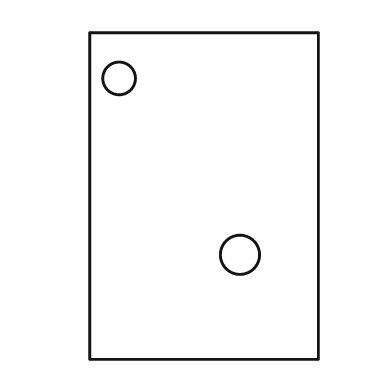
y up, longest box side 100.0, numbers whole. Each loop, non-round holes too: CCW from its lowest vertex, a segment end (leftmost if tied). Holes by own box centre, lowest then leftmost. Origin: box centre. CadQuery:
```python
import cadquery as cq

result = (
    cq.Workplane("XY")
    .moveTo(-35.0, -50.0)
    .lineTo(35.0, -50.0)
    .lineTo(35.0, 50.0)
    .lineTo(-35.0, 50.0)
    .close()
    .moveTo(11.0, -18.0)
    .circle(6.0)
    .moveTo(-26.0, 36.0)
    .circle(5.0)
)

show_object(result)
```